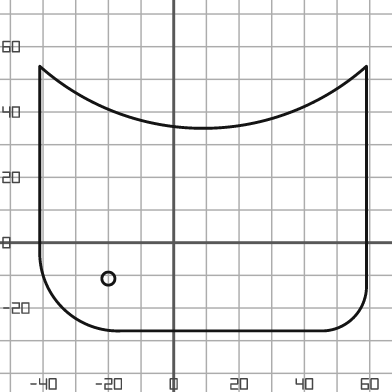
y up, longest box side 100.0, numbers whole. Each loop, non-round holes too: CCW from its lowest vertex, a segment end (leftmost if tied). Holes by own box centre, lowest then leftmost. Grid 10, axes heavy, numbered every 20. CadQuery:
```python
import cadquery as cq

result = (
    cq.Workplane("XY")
    .moveTo(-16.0, -27.0)
    .lineTo(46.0, -27.0)
    .threePointArc((55.0, -23.0), (59.0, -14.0))
    .lineTo(59.0, 54.0)
    .threePointArc((9.0, 35.0), (-41.0, 54.0))
    .lineTo(-41.0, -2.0)
    .threePointArc((-34.0, -20.0), (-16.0, -27.0))
    .close()
    .moveTo(-20.0, -11.0)
    .circle(2.0)
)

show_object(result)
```